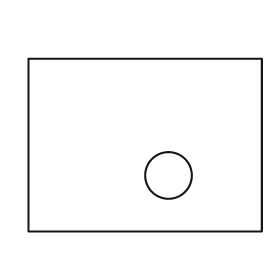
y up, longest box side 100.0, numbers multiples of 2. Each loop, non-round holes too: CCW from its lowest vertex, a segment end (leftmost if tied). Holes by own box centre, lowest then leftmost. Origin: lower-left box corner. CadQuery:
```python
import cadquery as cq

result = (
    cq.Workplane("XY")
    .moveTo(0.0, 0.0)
    .lineTo(100.0, 0.0)
    .lineTo(100.0, 74.0)
    .lineTo(0.0, 74.0)
    .close()
    .moveTo(60.0, 24.0)
    .circle(10.0)
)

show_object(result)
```